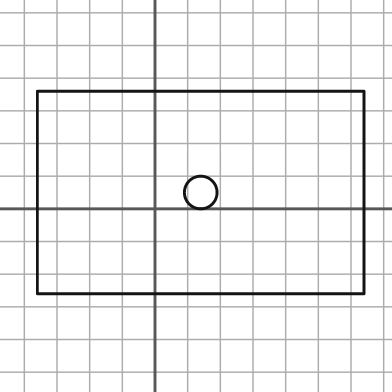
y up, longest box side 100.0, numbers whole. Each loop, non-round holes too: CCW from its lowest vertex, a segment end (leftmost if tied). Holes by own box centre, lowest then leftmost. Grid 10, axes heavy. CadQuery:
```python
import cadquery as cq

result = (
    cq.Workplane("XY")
    .moveTo(-36.0, -26.0)
    .lineTo(64.0, -26.0)
    .lineTo(64.0, 36.0)
    .lineTo(-36.0, 36.0)
    .close()
    .moveTo(14.0, 5.0)
    .circle(5.0)
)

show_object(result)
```